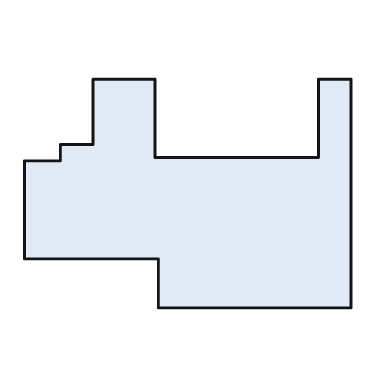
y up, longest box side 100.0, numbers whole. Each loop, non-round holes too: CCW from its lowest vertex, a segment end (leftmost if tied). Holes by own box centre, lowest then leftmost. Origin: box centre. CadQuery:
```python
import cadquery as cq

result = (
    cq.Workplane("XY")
    .moveTo(-9.0, -35.0)
    .lineTo(50.0, -35.0)
    .lineTo(50.0, 35.0)
    .lineTo(40.0, 35.0)
    .lineTo(40.0, 11.0)
    .lineTo(-10.0, 11.0)
    .lineTo(-10.0, 35.0)
    .lineTo(-29.0, 35.0)
    .lineTo(-29.0, 15.0)
    .lineTo(-39.0, 15.0)
    .lineTo(-39.0, 10.0)
    .lineTo(-50.0, 10.0)
    .lineTo(-50.0, -20.0)
    .lineTo(-9.0, -20.0)
    .close()
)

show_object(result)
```